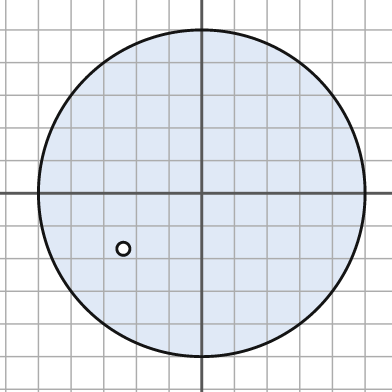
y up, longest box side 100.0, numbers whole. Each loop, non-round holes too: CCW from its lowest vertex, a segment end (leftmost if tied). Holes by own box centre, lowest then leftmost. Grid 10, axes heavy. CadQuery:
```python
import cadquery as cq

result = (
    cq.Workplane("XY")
    .moveTo(0.0, 0.0)
    .circle(50.0)
    .moveTo(-24.0, -17.0)
    .circle(2.0)
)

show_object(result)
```